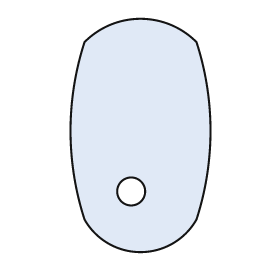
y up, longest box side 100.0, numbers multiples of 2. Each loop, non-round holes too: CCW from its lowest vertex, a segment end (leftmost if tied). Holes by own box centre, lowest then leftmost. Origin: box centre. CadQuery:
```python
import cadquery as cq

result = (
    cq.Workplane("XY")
    .moveTo(-24.0, -36.0)
    .threePointArc((0.0, -50.0), (24.0, -36.0))
    .threePointArc((30.0, 2.0), (24.0, 40.0))
    .threePointArc((0.0, 50.0), (-24.0, 40.0))
    .threePointArc((-30.0, 2.0), (-24.0, -36.0))
    .close()
    .moveTo(-4.0, -24.0)
    .circle(6.0)
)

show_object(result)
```